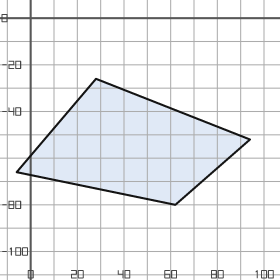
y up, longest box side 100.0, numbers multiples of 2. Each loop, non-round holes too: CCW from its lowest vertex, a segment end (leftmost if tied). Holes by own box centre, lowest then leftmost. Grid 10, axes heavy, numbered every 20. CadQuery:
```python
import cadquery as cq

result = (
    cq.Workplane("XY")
    .moveTo(62.0, -80.0)
    .lineTo(94.0, -52.0)
    .lineTo(28.0, -26.0)
    .lineTo(-6.0, -66.0)
    .close()
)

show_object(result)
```